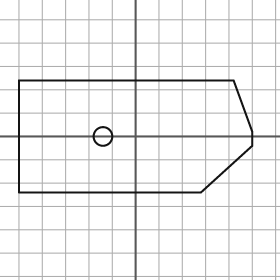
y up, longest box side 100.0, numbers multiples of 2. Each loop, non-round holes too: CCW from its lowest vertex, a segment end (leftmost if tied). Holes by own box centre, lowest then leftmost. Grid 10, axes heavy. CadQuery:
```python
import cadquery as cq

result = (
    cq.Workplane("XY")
    .moveTo(-50.0, -24.0)
    .lineTo(28.0, -24.0)
    .lineTo(50.0, -4.0)
    .lineTo(50.0, 2.0)
    .lineTo(42.0, 24.0)
    .lineTo(-50.0, 24.0)
    .close()
    .moveTo(-14.0, 0.0)
    .circle(4.0)
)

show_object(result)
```